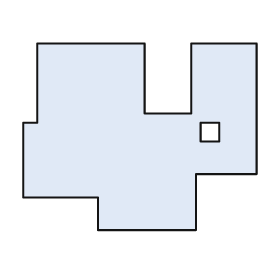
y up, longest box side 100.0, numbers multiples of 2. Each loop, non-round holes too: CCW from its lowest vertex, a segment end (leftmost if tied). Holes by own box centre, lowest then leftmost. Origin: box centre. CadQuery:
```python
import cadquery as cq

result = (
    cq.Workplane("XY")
    .moveTo(-18.0, -40.0)
    .lineTo(24.0, -40.0)
    .lineTo(24.0, -16.0)
    .lineTo(50.0, -16.0)
    .lineTo(50.0, 40.0)
    .lineTo(22.0, 40.0)
    .lineTo(22.0, 10.0)
    .lineTo(2.0, 10.0)
    .lineTo(2.0, 40.0)
    .lineTo(-44.0, 40.0)
    .lineTo(-44.0, 6.0)
    .lineTo(-50.0, 6.0)
    .lineTo(-50.0, -26.0)
    .lineTo(-18.0, -26.0)
    .close()
    .moveTo(26.0, -2.0)
    .lineTo(34.0, -2.0)
    .lineTo(34.0, 6.0)
    .lineTo(26.0, 6.0)
    .close()
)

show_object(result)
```